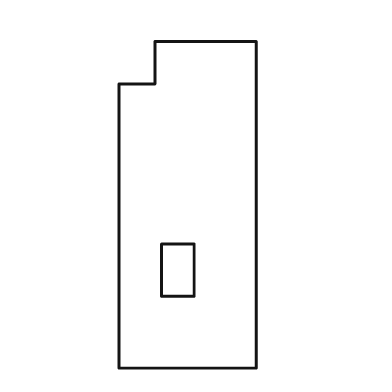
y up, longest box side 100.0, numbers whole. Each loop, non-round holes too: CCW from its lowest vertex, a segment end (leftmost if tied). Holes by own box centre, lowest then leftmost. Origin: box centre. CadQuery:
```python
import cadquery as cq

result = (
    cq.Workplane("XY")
    .moveTo(-21.0, -50.0)
    .lineTo(21.0, -50.0)
    .lineTo(21.0, 50.0)
    .lineTo(-10.0, 50.0)
    .lineTo(-10.0, 37.0)
    .lineTo(-21.0, 37.0)
    .close()
    .moveTo(-8.0, -28.0)
    .lineTo(2.0, -28.0)
    .lineTo(2.0, -12.0)
    .lineTo(-8.0, -12.0)
    .close()
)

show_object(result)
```